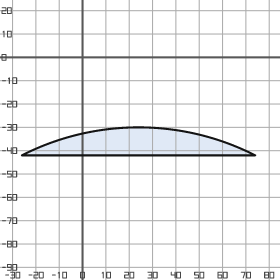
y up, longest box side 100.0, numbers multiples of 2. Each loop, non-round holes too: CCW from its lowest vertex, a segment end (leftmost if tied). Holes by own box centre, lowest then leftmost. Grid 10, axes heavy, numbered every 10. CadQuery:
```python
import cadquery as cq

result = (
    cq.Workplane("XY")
    .moveTo(-26.0, -42.0)
    .lineTo(74.0, -42.0)
    .threePointArc((24.0, -30.0), (-26.0, -42.0))
    .close()
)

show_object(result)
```